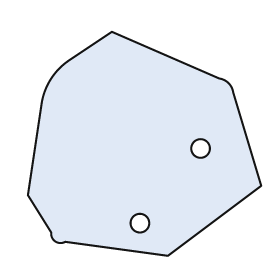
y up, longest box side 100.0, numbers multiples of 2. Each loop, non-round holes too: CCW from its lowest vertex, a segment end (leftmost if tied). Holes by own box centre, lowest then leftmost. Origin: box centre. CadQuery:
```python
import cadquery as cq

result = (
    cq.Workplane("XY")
    .moveTo(10.0, -48.0)
    .lineTo(50.0, -18.0)
    .lineTo(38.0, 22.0)
    .threePointArc((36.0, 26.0), (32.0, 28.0))
    .lineTo(-14.0, 48.0)
    .lineTo(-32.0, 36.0)
    .threePointArc((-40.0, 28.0), (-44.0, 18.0))
    .lineTo(-50.0, -22.0)
    .lineTo(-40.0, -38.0)
    .threePointArc((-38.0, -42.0), (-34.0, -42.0))
    .close()
    .moveTo(-2.0, -34.0)
    .circle(4.0)
    .moveTo(24.0, -2.0)
    .circle(4.0)
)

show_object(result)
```